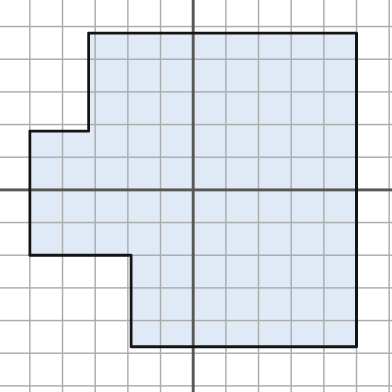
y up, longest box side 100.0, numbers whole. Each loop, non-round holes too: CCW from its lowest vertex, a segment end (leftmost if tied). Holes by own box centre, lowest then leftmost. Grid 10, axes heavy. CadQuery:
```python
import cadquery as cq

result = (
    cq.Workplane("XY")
    .moveTo(-19.0, -48.0)
    .lineTo(50.0, -48.0)
    .lineTo(50.0, 48.0)
    .lineTo(-32.0, 48.0)
    .lineTo(-32.0, 18.0)
    .lineTo(-50.0, 18.0)
    .lineTo(-50.0, -20.0)
    .lineTo(-19.0, -20.0)
    .close()
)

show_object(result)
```